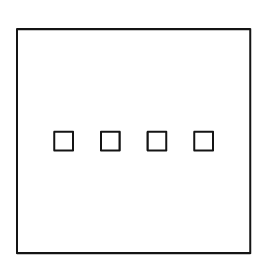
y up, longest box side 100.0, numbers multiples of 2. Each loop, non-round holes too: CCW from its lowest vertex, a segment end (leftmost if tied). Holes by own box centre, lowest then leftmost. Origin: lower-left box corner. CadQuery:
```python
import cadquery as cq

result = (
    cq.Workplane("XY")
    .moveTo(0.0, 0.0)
    .lineTo(100.0, 0.0)
    .lineTo(100.0, 96.0)
    .lineTo(0.0, 96.0)
    .close()
    .moveTo(16.0, 44.0)
    .lineTo(24.0, 44.0)
    .lineTo(24.0, 52.0)
    .lineTo(16.0, 52.0)
    .close()
    .moveTo(36.0, 44.0)
    .lineTo(44.0, 44.0)
    .lineTo(44.0, 52.0)
    .lineTo(36.0, 52.0)
    .close()
    .moveTo(56.0, 44.0)
    .lineTo(64.0, 44.0)
    .lineTo(64.0, 52.0)
    .lineTo(56.0, 52.0)
    .close()
    .moveTo(76.0, 44.0)
    .lineTo(84.0, 44.0)
    .lineTo(84.0, 52.0)
    .lineTo(76.0, 52.0)
    .close()
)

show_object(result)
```